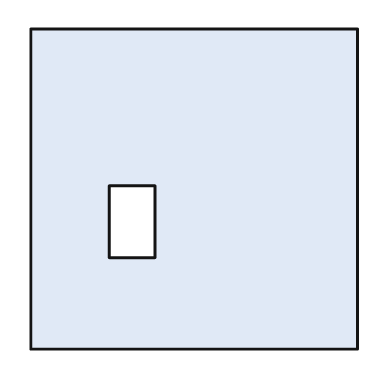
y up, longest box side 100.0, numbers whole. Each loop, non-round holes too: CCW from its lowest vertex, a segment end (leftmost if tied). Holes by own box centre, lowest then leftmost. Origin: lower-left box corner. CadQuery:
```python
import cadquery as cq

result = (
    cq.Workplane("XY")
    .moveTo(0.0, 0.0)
    .lineTo(100.0, 0.0)
    .lineTo(100.0, 98.0)
    .lineTo(0.0, 98.0)
    .close()
    .moveTo(24.0, 28.0)
    .lineTo(38.0, 28.0)
    .lineTo(38.0, 50.0)
    .lineTo(24.0, 50.0)
    .close()
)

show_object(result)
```